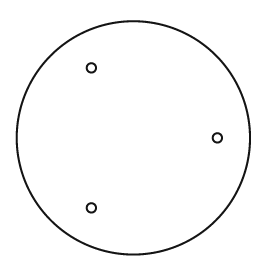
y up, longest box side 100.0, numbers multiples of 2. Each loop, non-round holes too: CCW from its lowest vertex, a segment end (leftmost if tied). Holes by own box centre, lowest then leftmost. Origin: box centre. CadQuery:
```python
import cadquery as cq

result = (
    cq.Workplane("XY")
    .moveTo(0.0, 0.0)
    .circle(50.0)
    .moveTo(-18.0, -30.0)
    .circle(2.0)
    .moveTo(36.0, 0.0)
    .circle(2.0)
    .moveTo(-18.0, 30.0)
    .circle(2.0)
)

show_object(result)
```